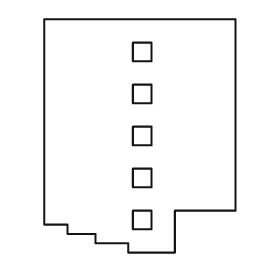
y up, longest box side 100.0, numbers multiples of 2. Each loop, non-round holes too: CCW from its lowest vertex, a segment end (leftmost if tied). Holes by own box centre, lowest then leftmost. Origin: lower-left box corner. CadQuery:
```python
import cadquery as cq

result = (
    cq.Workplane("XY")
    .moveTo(36.0, 0.0)
    .lineTo(56.0, 0.0)
    .lineTo(56.0, 18.0)
    .lineTo(82.0, 18.0)
    .lineTo(82.0, 100.0)
    .lineTo(0.0, 100.0)
    .lineTo(0.0, 12.0)
    .lineTo(10.0, 12.0)
    .lineTo(10.0, 8.0)
    .lineTo(22.0, 8.0)
    .lineTo(22.0, 4.0)
    .lineTo(36.0, 4.0)
    .close()
    .moveTo(38.0, 10.0)
    .lineTo(46.0, 10.0)
    .lineTo(46.0, 18.0)
    .lineTo(38.0, 18.0)
    .close()
    .moveTo(38.0, 28.0)
    .lineTo(46.0, 28.0)
    .lineTo(46.0, 36.0)
    .lineTo(38.0, 36.0)
    .close()
    .moveTo(38.0, 46.0)
    .lineTo(46.0, 46.0)
    .lineTo(46.0, 54.0)
    .lineTo(38.0, 54.0)
    .close()
    .moveTo(38.0, 64.0)
    .lineTo(46.0, 64.0)
    .lineTo(46.0, 72.0)
    .lineTo(38.0, 72.0)
    .close()
    .moveTo(38.0, 82.0)
    .lineTo(46.0, 82.0)
    .lineTo(46.0, 90.0)
    .lineTo(38.0, 90.0)
    .close()
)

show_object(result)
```